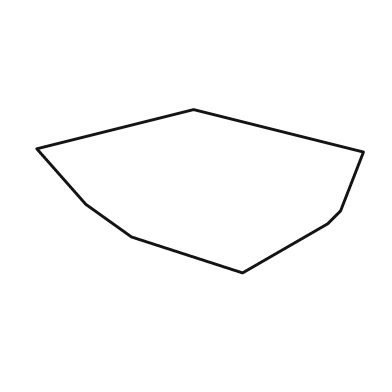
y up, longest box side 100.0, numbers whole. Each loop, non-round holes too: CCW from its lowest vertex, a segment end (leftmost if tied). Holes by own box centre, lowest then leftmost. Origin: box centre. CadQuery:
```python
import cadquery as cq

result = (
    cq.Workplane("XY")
    .moveTo(13.0, -25.0)
    .lineTo(39.0, -10.0)
    .lineTo(43.0, -6.0)
    .lineTo(50.0, 12.0)
    .lineTo(-2.0, 25.0)
    .lineTo(-50.0, 13.0)
    .lineTo(-35.0, -4.0)
    .lineTo(-21.0, -14.0)
    .close()
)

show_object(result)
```